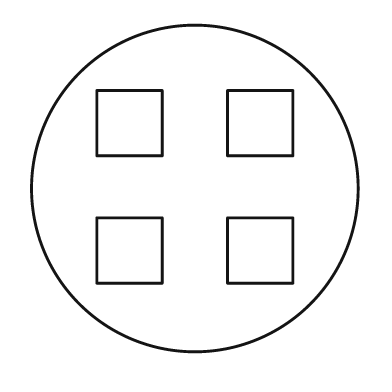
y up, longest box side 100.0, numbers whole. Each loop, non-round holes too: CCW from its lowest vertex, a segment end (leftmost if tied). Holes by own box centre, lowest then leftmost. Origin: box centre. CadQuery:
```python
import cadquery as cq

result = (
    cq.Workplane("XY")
    .moveTo(0.0, 0.0)
    .circle(50.0)
    .moveTo(-30.0, -29.0)
    .lineTo(-10.0, -29.0)
    .lineTo(-10.0, -9.0)
    .lineTo(-30.0, -9.0)
    .close()
    .moveTo(10.0, -29.0)
    .lineTo(30.0, -29.0)
    .lineTo(30.0, -9.0)
    .lineTo(10.0, -9.0)
    .close()
    .moveTo(-30.0, 10.0)
    .lineTo(-10.0, 10.0)
    .lineTo(-10.0, 30.0)
    .lineTo(-30.0, 30.0)
    .close()
    .moveTo(10.0, 10.0)
    .lineTo(30.0, 10.0)
    .lineTo(30.0, 30.0)
    .lineTo(10.0, 30.0)
    .close()
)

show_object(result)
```